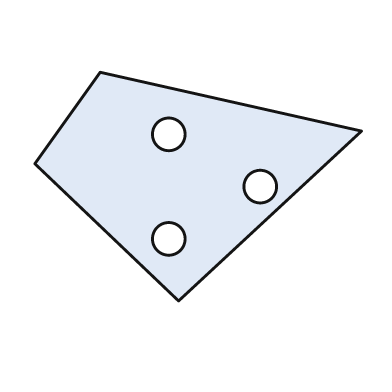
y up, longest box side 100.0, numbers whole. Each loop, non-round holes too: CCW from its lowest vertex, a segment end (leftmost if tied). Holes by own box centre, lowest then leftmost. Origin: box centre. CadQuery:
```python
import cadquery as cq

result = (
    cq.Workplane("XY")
    .moveTo(-6.0, -35.0)
    .lineTo(50.0, 17.0)
    .lineTo(-30.0, 35.0)
    .lineTo(-50.0, 7.0)
    .close()
    .moveTo(-9.0, -16.0)
    .circle(5.0)
    .moveTo(19.0, 0.0)
    .circle(5.0)
    .moveTo(-9.0, 16.0)
    .circle(5.0)
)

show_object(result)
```